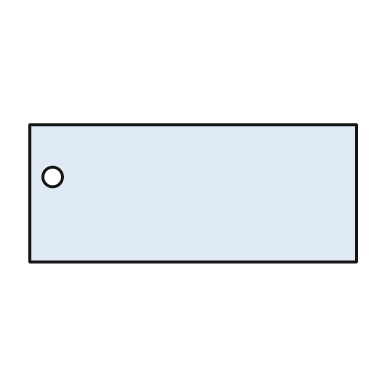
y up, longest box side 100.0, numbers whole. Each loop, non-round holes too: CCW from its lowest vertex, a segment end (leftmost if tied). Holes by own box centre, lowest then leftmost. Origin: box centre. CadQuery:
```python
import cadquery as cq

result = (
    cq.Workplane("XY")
    .moveTo(-50.0, -21.0)
    .lineTo(50.0, -21.0)
    .lineTo(50.0, 21.0)
    .lineTo(-50.0, 21.0)
    .close()
    .moveTo(-43.0, 5.0)
    .circle(3.0)
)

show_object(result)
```